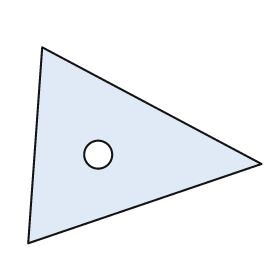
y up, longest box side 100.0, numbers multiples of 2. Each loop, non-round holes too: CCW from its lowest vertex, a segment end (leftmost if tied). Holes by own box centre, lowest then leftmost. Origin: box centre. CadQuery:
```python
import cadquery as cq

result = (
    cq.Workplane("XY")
    .moveTo(-50.0, -42.0)
    .lineTo(50.0, -8.0)
    .lineTo(-44.0, 42.0)
    .close()
    .moveTo(-20.0, -4.0)
    .circle(6.0)
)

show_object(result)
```